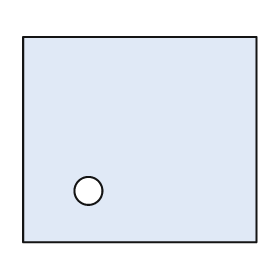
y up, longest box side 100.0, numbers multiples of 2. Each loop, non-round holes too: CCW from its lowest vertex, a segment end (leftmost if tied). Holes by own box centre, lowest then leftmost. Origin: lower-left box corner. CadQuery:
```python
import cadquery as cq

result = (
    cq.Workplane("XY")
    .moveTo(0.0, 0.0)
    .lineTo(100.0, 0.0)
    .lineTo(100.0, 88.0)
    .lineTo(0.0, 88.0)
    .close()
    .moveTo(28.0, 22.0)
    .circle(6.0)
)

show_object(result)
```